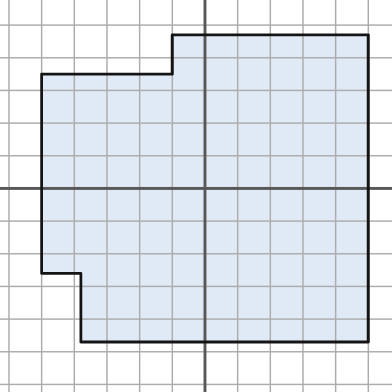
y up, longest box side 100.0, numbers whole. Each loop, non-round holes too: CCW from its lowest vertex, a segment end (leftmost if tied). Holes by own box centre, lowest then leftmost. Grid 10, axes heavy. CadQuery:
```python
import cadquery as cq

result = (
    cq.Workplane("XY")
    .moveTo(-38.0, -47.0)
    .lineTo(50.0, -47.0)
    .lineTo(50.0, 47.0)
    .lineTo(-10.0, 47.0)
    .lineTo(-10.0, 35.0)
    .lineTo(-50.0, 35.0)
    .lineTo(-50.0, -26.0)
    .lineTo(-38.0, -26.0)
    .close()
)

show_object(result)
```